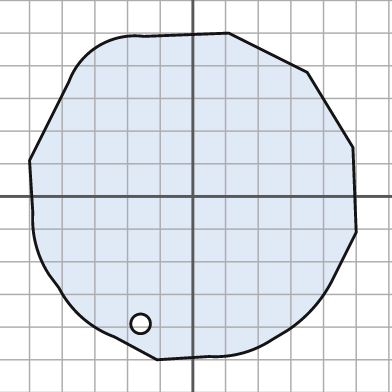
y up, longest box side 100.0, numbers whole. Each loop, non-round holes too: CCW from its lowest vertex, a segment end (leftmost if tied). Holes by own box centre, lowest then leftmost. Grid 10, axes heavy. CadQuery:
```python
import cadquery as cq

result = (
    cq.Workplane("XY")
    .moveTo(-11.0, -50.0)
    .lineTo(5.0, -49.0)
    .threePointArc((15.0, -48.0), (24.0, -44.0))
    .lineTo(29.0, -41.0)
    .threePointArc((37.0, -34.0), (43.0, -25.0))
    .lineTo(50.0, -11.0)
    .lineTo(49.0, 15.0)
    .lineTo(35.0, 38.0)
    .lineTo(11.0, 50.0)
    .lineTo(-15.0, 49.0)
    .threePointArc((-29.0, 46.0), (-38.0, 35.0))
    .lineTo(-50.0, 11.0)
    .lineTo(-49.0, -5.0)
    .threePointArc((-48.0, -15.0), (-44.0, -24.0))
    .lineTo(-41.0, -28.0)
    .threePointArc((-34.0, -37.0), (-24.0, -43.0))
    .close()
    .moveTo(-16.0, -39.0)
    .circle(3.0)
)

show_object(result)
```